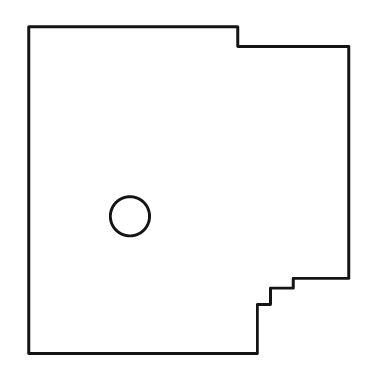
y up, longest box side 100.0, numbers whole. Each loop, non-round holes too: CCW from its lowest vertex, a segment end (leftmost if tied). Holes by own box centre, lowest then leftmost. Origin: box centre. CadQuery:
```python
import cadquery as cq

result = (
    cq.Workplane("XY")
    .moveTo(-49.0, -50.0)
    .lineTo(21.0, -50.0)
    .lineTo(21.0, -35.0)
    .lineTo(25.0, -35.0)
    .lineTo(25.0, -30.0)
    .lineTo(32.0, -30.0)
    .lineTo(32.0, -27.0)
    .lineTo(49.0, -27.0)
    .lineTo(49.0, 44.0)
    .lineTo(15.0, 44.0)
    .lineTo(15.0, 50.0)
    .lineTo(-49.0, 50.0)
    .close()
    .moveTo(-18.0, -8.0)
    .circle(6.0)
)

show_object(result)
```